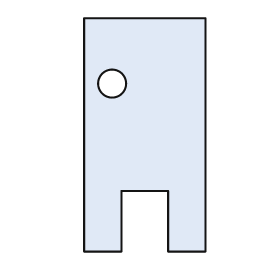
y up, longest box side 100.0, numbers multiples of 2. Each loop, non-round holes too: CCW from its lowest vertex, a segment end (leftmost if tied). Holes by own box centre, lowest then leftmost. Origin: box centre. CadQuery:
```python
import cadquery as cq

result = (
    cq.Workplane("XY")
    .moveTo(-26.0, -50.0)
    .lineTo(-10.0, -50.0)
    .lineTo(-10.0, -24.0)
    .lineTo(10.0, -24.0)
    .lineTo(10.0, -50.0)
    .lineTo(26.0, -50.0)
    .lineTo(26.0, 50.0)
    .lineTo(-26.0, 50.0)
    .close()
    .moveTo(-14.0, 22.0)
    .circle(6.0)
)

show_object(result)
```